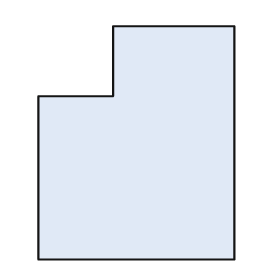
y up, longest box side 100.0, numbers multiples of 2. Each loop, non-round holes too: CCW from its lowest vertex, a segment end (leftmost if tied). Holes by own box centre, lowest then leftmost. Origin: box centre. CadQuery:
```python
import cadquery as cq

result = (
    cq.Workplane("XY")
    .moveTo(-42.0, -50.0)
    .lineTo(42.0, -50.0)
    .lineTo(42.0, 50.0)
    .lineTo(-10.0, 50.0)
    .lineTo(-10.0, 20.0)
    .lineTo(-42.0, 20.0)
    .close()
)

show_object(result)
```